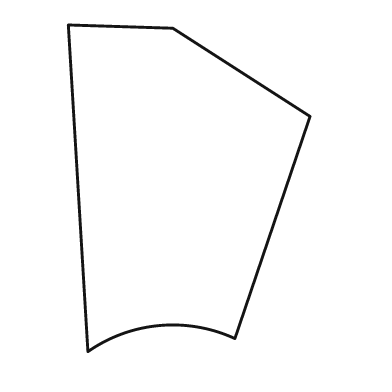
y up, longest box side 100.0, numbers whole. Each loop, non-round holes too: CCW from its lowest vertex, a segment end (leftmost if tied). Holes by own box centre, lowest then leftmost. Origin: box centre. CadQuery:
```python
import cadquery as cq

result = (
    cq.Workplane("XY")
    .moveTo(-31.0, -50.0)
    .threePointArc((-9.0, -42.0), (14.0, -46.0))
    .lineTo(37.0, 22.0)
    .lineTo(-5.0, 49.0)
    .lineTo(-37.0, 50.0)
    .close()
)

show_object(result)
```